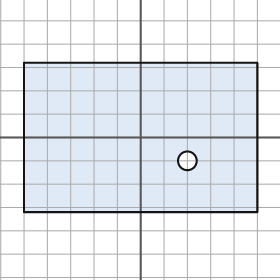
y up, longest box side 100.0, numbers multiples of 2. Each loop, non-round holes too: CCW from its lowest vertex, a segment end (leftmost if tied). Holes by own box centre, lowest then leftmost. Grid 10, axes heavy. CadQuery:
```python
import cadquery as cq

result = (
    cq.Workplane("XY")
    .moveTo(-50.0, -32.0)
    .lineTo(50.0, -32.0)
    .lineTo(50.0, 32.0)
    .lineTo(-50.0, 32.0)
    .close()
    .moveTo(20.0, -10.0)
    .circle(4.0)
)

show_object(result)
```